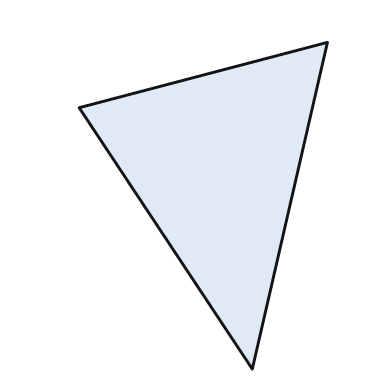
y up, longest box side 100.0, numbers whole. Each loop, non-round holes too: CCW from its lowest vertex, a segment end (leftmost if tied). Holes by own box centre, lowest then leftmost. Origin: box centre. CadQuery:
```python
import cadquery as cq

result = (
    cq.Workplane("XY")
    .moveTo(15.0, -50.0)
    .lineTo(38.0, 50.0)
    .lineTo(-38.0, 30.0)
    .close()
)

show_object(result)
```